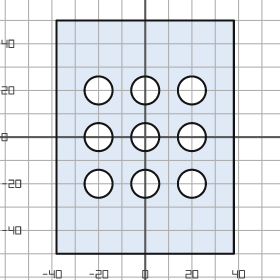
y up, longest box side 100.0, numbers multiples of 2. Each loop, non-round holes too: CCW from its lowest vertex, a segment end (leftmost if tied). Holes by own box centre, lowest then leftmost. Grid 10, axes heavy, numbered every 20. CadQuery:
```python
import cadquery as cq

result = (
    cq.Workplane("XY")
    .moveTo(-38.0, -50.0)
    .lineTo(38.0, -50.0)
    .lineTo(38.0, 50.0)
    .lineTo(-38.0, 50.0)
    .close()
    .moveTo(-20.0, -20.0)
    .circle(6.0)
    .moveTo(0.0, -20.0)
    .circle(6.0)
    .moveTo(20.0, -20.0)
    .circle(6.0)
    .moveTo(-20.0, 0.0)
    .circle(6.0)
    .moveTo(0.0, 0.0)
    .circle(6.0)
    .moveTo(20.0, 0.0)
    .circle(6.0)
    .moveTo(-20.0, 20.0)
    .circle(6.0)
    .moveTo(0.0, 20.0)
    .circle(6.0)
    .moveTo(20.0, 20.0)
    .circle(6.0)
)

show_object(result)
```